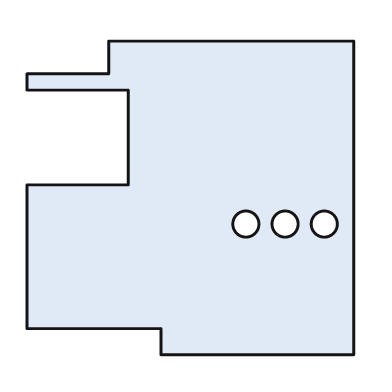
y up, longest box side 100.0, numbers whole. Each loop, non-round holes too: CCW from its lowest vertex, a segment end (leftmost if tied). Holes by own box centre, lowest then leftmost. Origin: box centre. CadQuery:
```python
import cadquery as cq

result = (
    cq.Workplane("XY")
    .moveTo(-9.0, -48.0)
    .lineTo(50.0, -48.0)
    .lineTo(50.0, 48.0)
    .lineTo(-25.0, 48.0)
    .lineTo(-25.0, 38.0)
    .lineTo(-50.0, 38.0)
    .lineTo(-50.0, 33.0)
    .lineTo(-19.0, 33.0)
    .lineTo(-19.0, 4.0)
    .lineTo(-50.0, 4.0)
    .lineTo(-50.0, -40.0)
    .lineTo(-9.0, -40.0)
    .close()
    .moveTo(17.0, -8.0)
    .circle(4.0)
    .moveTo(29.0, -8.0)
    .circle(4.0)
    .moveTo(41.0, -8.0)
    .circle(4.0)
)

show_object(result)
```